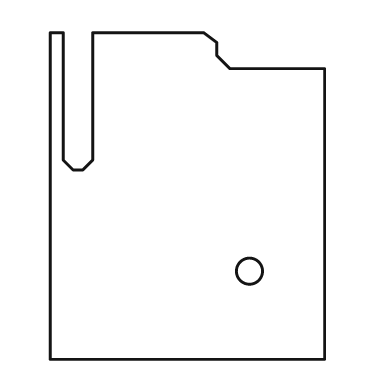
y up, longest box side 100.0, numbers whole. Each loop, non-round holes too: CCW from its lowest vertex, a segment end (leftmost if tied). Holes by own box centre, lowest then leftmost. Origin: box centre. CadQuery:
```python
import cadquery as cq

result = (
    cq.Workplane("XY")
    .moveTo(-42.0, -50.0)
    .lineTo(42.0, -50.0)
    .lineTo(42.0, 39.0)
    .lineTo(13.0, 39.0)
    .lineTo(9.0, 43.0)
    .lineTo(9.0, 47.0)
    .lineTo(5.0, 50.0)
    .lineTo(-29.0, 50.0)
    .lineTo(-29.0, 11.0)
    .lineTo(-32.0, 8.0)
    .lineTo(-35.0, 8.0)
    .lineTo(-38.0, 11.0)
    .lineTo(-38.0, 50.0)
    .lineTo(-42.0, 50.0)
    .close()
    .moveTo(19.0, -23.0)
    .circle(4.0)
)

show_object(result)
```